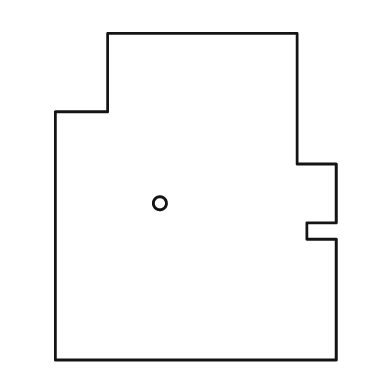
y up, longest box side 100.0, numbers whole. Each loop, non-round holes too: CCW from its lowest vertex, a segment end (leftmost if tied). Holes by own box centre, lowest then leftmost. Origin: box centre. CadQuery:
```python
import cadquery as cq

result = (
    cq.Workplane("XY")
    .moveTo(-43.0, -50.0)
    .lineTo(43.0, -50.0)
    .lineTo(43.0, -13.0)
    .lineTo(34.0, -13.0)
    .lineTo(34.0, -8.0)
    .lineTo(43.0, -8.0)
    .lineTo(43.0, 10.0)
    .lineTo(31.0, 10.0)
    .lineTo(31.0, 50.0)
    .lineTo(-27.0, 50.0)
    .lineTo(-27.0, 26.0)
    .lineTo(-43.0, 26.0)
    .close()
    .moveTo(-11.0, -2.0)
    .circle(2.0)
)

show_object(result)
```